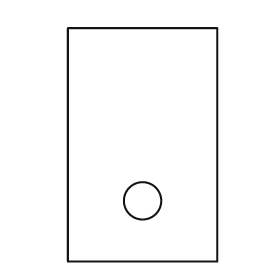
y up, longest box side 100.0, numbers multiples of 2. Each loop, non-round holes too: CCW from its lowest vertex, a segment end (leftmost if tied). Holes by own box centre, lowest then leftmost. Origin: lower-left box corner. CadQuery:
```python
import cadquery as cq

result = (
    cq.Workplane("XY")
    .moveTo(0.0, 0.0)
    .lineTo(64.0, 0.0)
    .lineTo(64.0, 100.0)
    .lineTo(0.0, 100.0)
    .close()
    .moveTo(32.0, 26.0)
    .circle(8.0)
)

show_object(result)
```